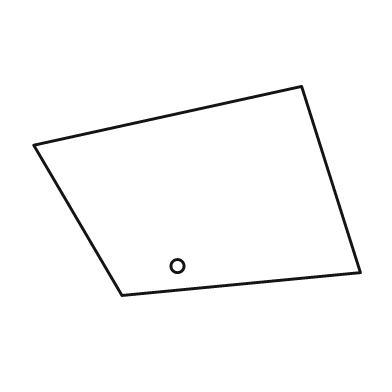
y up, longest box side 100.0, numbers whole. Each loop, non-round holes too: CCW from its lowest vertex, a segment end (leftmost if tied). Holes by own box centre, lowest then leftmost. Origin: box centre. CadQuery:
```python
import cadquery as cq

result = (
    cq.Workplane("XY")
    .moveTo(-23.0, -32.0)
    .lineTo(50.0, -25.0)
    .lineTo(32.0, 32.0)
    .lineTo(-50.0, 14.0)
    .close()
    .moveTo(-6.0, -23.0)
    .circle(2.0)
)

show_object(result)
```